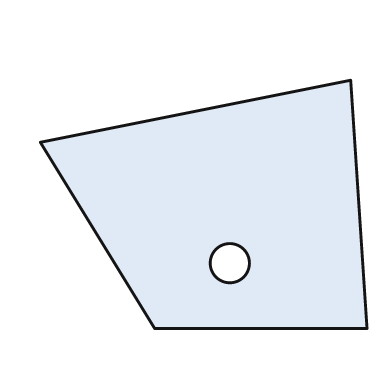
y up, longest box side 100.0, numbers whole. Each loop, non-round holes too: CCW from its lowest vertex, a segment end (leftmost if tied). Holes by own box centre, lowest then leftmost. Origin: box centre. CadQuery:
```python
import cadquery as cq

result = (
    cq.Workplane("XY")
    .moveTo(-15.0, -38.0)
    .lineTo(50.0, -38.0)
    .lineTo(45.0, 38.0)
    .lineTo(-50.0, 19.0)
    .close()
    .moveTo(8.0, -18.0)
    .circle(6.0)
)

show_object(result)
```